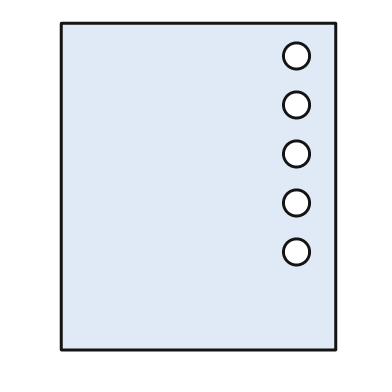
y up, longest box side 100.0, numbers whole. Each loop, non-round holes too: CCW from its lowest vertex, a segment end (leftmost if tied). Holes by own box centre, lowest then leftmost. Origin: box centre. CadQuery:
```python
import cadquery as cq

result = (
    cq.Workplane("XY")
    .moveTo(-42.0, -50.0)
    .lineTo(42.0, -50.0)
    .lineTo(42.0, 50.0)
    .lineTo(-42.0, 50.0)
    .close()
    .moveTo(30.0, -20.0)
    .circle(4.0)
    .moveTo(30.0, -5.0)
    .circle(4.0)
    .moveTo(30.0, 10.0)
    .circle(4.0)
    .moveTo(30.0, 25.0)
    .circle(4.0)
    .moveTo(30.0, 40.0)
    .circle(4.0)
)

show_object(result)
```